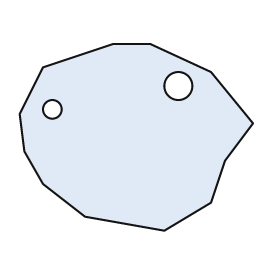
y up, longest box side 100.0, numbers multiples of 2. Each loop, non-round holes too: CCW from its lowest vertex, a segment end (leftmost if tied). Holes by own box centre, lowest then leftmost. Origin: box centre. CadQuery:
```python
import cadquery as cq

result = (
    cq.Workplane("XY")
    .moveTo(12.0, -40.0)
    .lineTo(32.0, -28.0)
    .lineTo(38.0, -10.0)
    .lineTo(50.0, 6.0)
    .lineTo(32.0, 28.0)
    .lineTo(6.0, 40.0)
    .lineTo(-10.0, 40.0)
    .lineTo(-40.0, 30.0)
    .lineTo(-50.0, 10.0)
    .lineTo(-48.0, -6.0)
    .lineTo(-40.0, -20.0)
    .lineTo(-22.0, -34.0)
    .close()
    .moveTo(-36.0, 12.0)
    .circle(4.0)
    .moveTo(18.0, 22.0)
    .circle(6.0)
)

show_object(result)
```